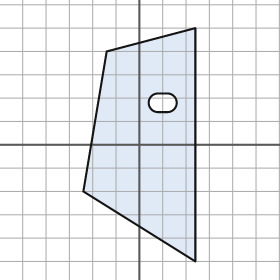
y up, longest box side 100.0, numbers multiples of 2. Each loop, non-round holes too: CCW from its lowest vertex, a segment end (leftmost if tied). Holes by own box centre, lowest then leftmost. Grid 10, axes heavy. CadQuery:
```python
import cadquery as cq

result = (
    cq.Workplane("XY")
    .moveTo(24.0, -50.0)
    .lineTo(24.0, 50.0)
    .lineTo(-14.0, 40.0)
    .lineTo(-24.0, -20.0)
    .close()
    .moveTo(8.0, 14.0)
    .lineTo(12.0, 14.0)
    .threePointArc((16.0, 18.0), (12.0, 22.0))
    .lineTo(8.0, 22.0)
    .threePointArc((4.0, 18.0), (8.0, 14.0))
    .close()
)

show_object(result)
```